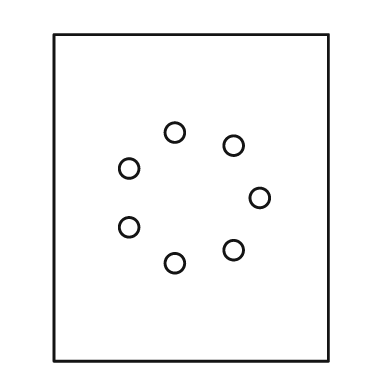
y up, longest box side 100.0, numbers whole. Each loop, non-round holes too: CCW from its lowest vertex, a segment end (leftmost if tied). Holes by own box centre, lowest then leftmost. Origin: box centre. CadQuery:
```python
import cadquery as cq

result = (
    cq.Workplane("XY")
    .moveTo(-42.0, -50.0)
    .lineTo(42.0, -50.0)
    .lineTo(42.0, 50.0)
    .lineTo(-42.0, 50.0)
    .close()
    .moveTo(-5.0, -20.0)
    .circle(3.0)
    .moveTo(13.0, -16.0)
    .circle(3.0)
    .moveTo(-19.0, -9.0)
    .circle(3.0)
    .moveTo(21.0, 0.0)
    .circle(3.0)
    .moveTo(-19.0, 9.0)
    .circle(3.0)
    .moveTo(13.0, 16.0)
    .circle(3.0)
    .moveTo(-5.0, 20.0)
    .circle(3.0)
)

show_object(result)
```